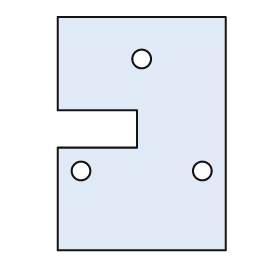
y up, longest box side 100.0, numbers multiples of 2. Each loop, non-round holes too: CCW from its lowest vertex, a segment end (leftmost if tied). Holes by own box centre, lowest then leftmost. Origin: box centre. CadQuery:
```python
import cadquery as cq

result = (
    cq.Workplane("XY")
    .moveTo(-36.0, -50.0)
    .lineTo(36.0, -50.0)
    .lineTo(36.0, 50.0)
    .lineTo(-36.0, 50.0)
    .lineTo(-36.0, 10.0)
    .lineTo(-2.0, 10.0)
    .lineTo(-2.0, -6.0)
    .lineTo(-36.0, -6.0)
    .close()
    .moveTo(-26.0, -16.0)
    .circle(4.0)
    .moveTo(26.0, -16.0)
    .circle(4.0)
    .moveTo(0.0, 32.0)
    .circle(4.0)
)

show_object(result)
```